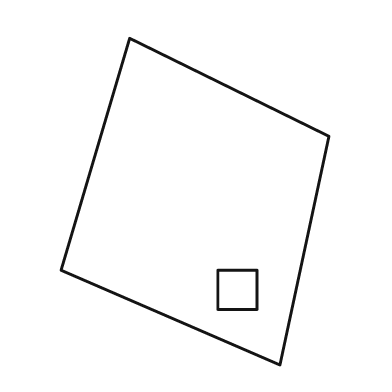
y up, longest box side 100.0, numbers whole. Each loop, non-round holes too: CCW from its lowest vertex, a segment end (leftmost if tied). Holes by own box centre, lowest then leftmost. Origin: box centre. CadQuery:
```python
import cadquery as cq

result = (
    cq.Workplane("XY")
    .moveTo(26.0, -50.0)
    .lineTo(41.0, 20.0)
    .lineTo(-20.0, 50.0)
    .lineTo(-41.0, -21.0)
    .close()
    .moveTo(7.0, -33.0)
    .lineTo(19.0, -33.0)
    .lineTo(19.0, -21.0)
    .lineTo(7.0, -21.0)
    .close()
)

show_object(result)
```